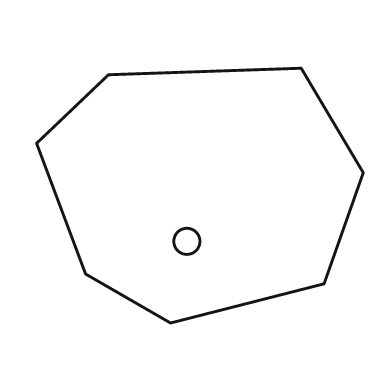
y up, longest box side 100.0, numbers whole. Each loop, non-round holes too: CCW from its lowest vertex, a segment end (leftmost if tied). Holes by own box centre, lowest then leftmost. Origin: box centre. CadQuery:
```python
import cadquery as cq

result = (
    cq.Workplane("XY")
    .moveTo(-9.0, -39.0)
    .lineTo(38.0, -27.0)
    .lineTo(50.0, 7.0)
    .lineTo(31.0, 39.0)
    .lineTo(-28.0, 37.0)
    .lineTo(-50.0, 16.0)
    .lineTo(-35.0, -24.0)
    .close()
    .moveTo(-4.0, -14.0)
    .circle(4.0)
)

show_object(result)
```